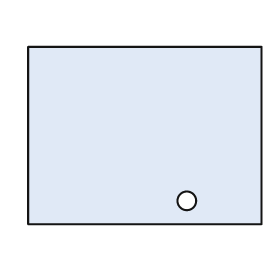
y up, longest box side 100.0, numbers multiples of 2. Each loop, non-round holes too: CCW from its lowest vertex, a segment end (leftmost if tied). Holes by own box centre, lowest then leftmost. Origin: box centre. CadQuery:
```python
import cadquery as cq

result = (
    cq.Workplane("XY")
    .moveTo(-50.0, -38.0)
    .lineTo(50.0, -38.0)
    .lineTo(50.0, 38.0)
    .lineTo(-50.0, 38.0)
    .close()
    .moveTo(18.0, -28.0)
    .circle(4.0)
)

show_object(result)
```